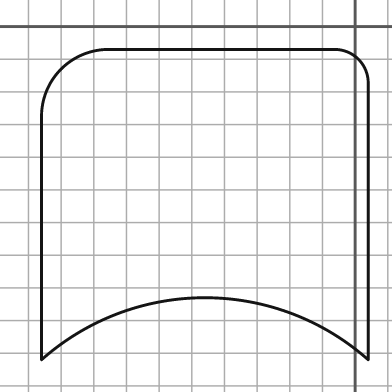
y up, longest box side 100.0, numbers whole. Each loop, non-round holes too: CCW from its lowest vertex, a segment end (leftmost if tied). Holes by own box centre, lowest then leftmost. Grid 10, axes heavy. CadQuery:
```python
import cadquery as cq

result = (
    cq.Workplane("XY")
    .moveTo(-96.0, -102.0)
    .threePointArc((-46.0, -83.0), (4.0, -102.0))
    .lineTo(4.0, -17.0)
    .threePointArc((1.0, -10.0), (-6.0, -7.0))
    .lineTo(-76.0, -7.0)
    .threePointArc((-90.0, -13.0), (-96.0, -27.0))
    .close()
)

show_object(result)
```